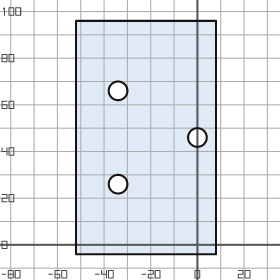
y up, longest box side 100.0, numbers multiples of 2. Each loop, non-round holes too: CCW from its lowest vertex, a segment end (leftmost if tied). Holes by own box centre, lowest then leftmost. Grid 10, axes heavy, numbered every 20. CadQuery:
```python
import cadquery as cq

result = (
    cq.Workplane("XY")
    .moveTo(-52.0, -4.0)
    .lineTo(8.0, -4.0)
    .lineTo(8.0, 96.0)
    .lineTo(-52.0, 96.0)
    .close()
    .moveTo(-34.0, 26.0)
    .circle(4.0)
    .moveTo(0.0, 46.0)
    .circle(4.0)
    .moveTo(-34.0, 66.0)
    .circle(4.0)
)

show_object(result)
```